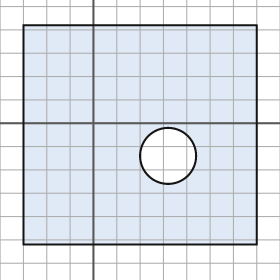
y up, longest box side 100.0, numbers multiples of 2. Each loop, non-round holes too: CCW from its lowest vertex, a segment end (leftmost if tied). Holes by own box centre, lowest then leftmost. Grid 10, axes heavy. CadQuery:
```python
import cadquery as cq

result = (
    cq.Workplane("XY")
    .moveTo(-30.0, -52.0)
    .lineTo(70.0, -52.0)
    .lineTo(70.0, 42.0)
    .lineTo(-30.0, 42.0)
    .close()
    .moveTo(32.0, -14.0)
    .circle(12.0)
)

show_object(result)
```